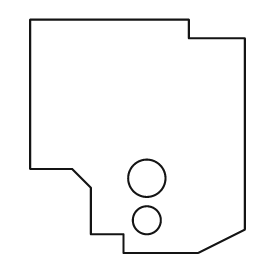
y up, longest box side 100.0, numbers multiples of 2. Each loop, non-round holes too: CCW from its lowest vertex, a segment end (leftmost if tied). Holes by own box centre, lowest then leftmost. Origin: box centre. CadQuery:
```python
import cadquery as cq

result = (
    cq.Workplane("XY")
    .moveTo(-6.0, -50.0)
    .lineTo(26.0, -50.0)
    .lineTo(46.0, -40.0)
    .lineTo(46.0, 42.0)
    .lineTo(22.0, 42.0)
    .lineTo(22.0, 50.0)
    .lineTo(-46.0, 50.0)
    .lineTo(-46.0, -14.0)
    .lineTo(-28.0, -14.0)
    .lineTo(-20.0, -22.0)
    .lineTo(-20.0, -42.0)
    .lineTo(-6.0, -42.0)
    .close()
    .moveTo(4.0, -36.0)
    .circle(6.0)
    .moveTo(4.0, -18.0)
    .circle(8.0)
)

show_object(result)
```